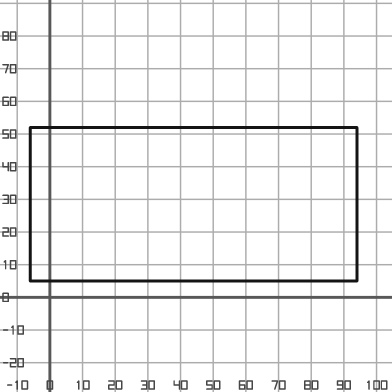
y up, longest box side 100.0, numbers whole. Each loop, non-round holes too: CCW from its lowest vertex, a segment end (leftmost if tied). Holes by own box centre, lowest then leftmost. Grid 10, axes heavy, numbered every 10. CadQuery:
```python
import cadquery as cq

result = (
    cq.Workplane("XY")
    .moveTo(-6.0, 5.0)
    .lineTo(94.0, 5.0)
    .lineTo(94.0, 52.0)
    .lineTo(-6.0, 52.0)
    .close()
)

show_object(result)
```